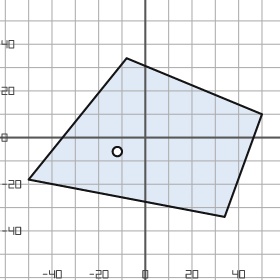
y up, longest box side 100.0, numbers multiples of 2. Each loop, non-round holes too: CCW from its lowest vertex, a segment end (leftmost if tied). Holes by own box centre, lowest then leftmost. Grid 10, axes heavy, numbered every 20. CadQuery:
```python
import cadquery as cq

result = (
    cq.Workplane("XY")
    .moveTo(34.0, -34.0)
    .lineTo(50.0, 10.0)
    .lineTo(-8.0, 34.0)
    .lineTo(-50.0, -18.0)
    .close()
    .moveTo(-12.0, -6.0)
    .circle(2.0)
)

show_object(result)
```